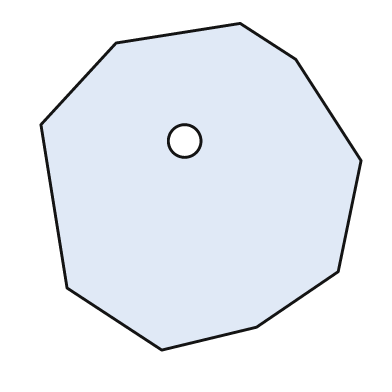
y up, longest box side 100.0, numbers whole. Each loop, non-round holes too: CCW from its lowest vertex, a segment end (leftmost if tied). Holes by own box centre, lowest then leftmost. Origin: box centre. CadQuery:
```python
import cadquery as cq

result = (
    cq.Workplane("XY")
    .moveTo(-12.0, -50.0)
    .lineTo(17.0, -43.0)
    .lineTo(42.0, -26.0)
    .lineTo(49.0, 8.0)
    .lineTo(29.0, 39.0)
    .lineTo(12.0, 50.0)
    .lineTo(-26.0, 44.0)
    .lineTo(-49.0, 19.0)
    .lineTo(-41.0, -31.0)
    .close()
    .moveTo(-5.0, 14.0)
    .circle(5.0)
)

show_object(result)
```